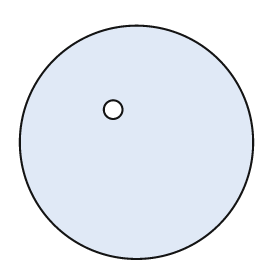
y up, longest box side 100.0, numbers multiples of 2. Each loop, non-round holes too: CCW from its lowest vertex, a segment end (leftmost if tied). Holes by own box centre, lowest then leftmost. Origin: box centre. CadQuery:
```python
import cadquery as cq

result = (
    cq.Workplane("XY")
    .moveTo(0.0, 0.0)
    .circle(50.0)
    .moveTo(-10.0, 14.0)
    .circle(4.0)
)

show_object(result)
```